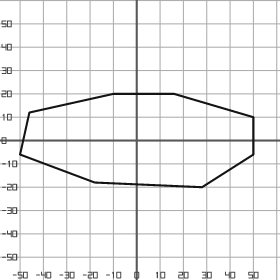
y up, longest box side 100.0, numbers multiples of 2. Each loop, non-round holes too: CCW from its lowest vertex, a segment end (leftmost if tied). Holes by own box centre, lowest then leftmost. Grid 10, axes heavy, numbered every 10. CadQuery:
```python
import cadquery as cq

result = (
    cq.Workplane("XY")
    .moveTo(28.0, -20.0)
    .lineTo(50.0, -6.0)
    .lineTo(50.0, 10.0)
    .lineTo(16.0, 20.0)
    .lineTo(-10.0, 20.0)
    .lineTo(-46.0, 12.0)
    .lineTo(-50.0, -6.0)
    .lineTo(-18.0, -18.0)
    .close()
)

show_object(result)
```